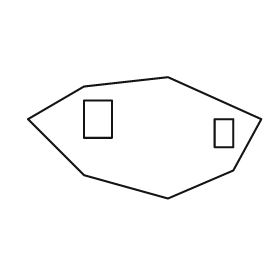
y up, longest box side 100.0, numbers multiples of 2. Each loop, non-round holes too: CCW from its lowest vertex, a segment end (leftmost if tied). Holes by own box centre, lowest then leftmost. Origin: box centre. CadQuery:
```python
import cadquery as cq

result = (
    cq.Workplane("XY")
    .moveTo(10.0, -26.0)
    .lineTo(38.0, -14.0)
    .lineTo(50.0, 8.0)
    .lineTo(10.0, 26.0)
    .lineTo(-26.0, 22.0)
    .lineTo(-50.0, 8.0)
    .lineTo(-26.0, -16.0)
    .close()
    .moveTo(30.0, -4.0)
    .lineTo(38.0, -4.0)
    .lineTo(38.0, 8.0)
    .lineTo(30.0, 8.0)
    .close()
    .moveTo(-26.0, 0.0)
    .lineTo(-14.0, 0.0)
    .lineTo(-14.0, 16.0)
    .lineTo(-26.0, 16.0)
    .close()
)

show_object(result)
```